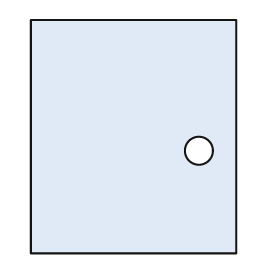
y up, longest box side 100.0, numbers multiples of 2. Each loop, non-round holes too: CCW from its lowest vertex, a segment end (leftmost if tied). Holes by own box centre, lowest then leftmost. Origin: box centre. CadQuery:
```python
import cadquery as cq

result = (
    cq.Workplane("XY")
    .moveTo(-44.0, -50.0)
    .lineTo(44.0, -50.0)
    .lineTo(44.0, 50.0)
    .lineTo(-44.0, 50.0)
    .close()
    .moveTo(28.0, -6.0)
    .circle(6.0)
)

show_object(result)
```